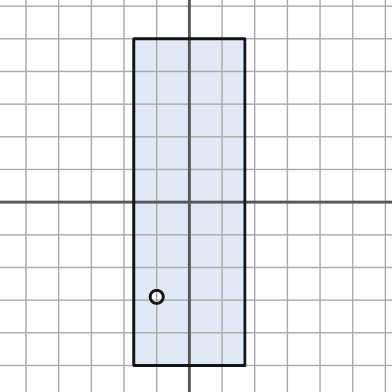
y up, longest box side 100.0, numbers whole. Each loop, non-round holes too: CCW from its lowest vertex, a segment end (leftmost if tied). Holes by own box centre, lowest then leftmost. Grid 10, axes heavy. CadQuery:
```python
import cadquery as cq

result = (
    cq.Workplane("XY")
    .moveTo(-17.0, -50.0)
    .lineTo(17.0, -50.0)
    .lineTo(17.0, 50.0)
    .lineTo(-17.0, 50.0)
    .close()
    .moveTo(-10.0, -29.0)
    .circle(2.0)
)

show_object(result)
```